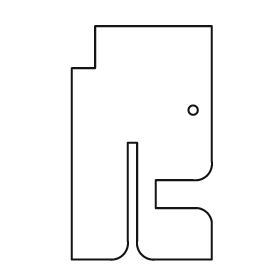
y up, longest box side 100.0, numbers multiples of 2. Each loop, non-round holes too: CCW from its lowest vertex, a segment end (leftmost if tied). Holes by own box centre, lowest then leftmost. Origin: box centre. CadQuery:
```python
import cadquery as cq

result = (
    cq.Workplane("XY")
    .moveTo(-30.0, -50.0)
    .lineTo(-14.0, -50.0)
    .threePointArc((-8.0, -48.0), (-6.0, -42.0))
    .lineTo(-6.0, 0.0)
    .lineTo(-2.0, 0.0)
    .lineTo(-2.0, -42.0)
    .threePointArc((0.0, -48.0), (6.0, -50.0))
    .lineTo(30.0, -50.0)
    .lineTo(30.0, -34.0)
    .threePointArc((28.0, -30.0), (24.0, -28.0))
    .lineTo(6.0, -28.0)
    .lineTo(6.0, -16.0)
    .lineTo(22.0, -16.0)
    .threePointArc((28.0, -14.0), (30.0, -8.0))
    .lineTo(30.0, 50.0)
    .lineTo(-20.0, 50.0)
    .lineTo(-20.0, 32.0)
    .lineTo(-30.0, 32.0)
    .close()
    .moveTo(22.0, 14.0)
    .circle(2.0)
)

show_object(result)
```